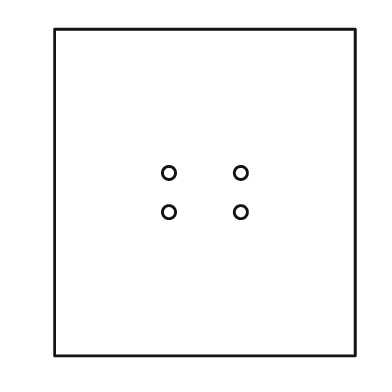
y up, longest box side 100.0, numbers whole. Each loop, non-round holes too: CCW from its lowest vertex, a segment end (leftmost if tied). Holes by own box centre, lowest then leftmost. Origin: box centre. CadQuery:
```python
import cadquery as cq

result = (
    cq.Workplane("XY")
    .moveTo(-46.0, -50.0)
    .lineTo(46.0, -50.0)
    .lineTo(46.0, 50.0)
    .lineTo(-46.0, 50.0)
    .close()
    .moveTo(-11.0, -6.0)
    .circle(2.0)
    .moveTo(11.0, -6.0)
    .circle(2.0)
    .moveTo(-11.0, 6.0)
    .circle(2.0)
    .moveTo(11.0, 6.0)
    .circle(2.0)
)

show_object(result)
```